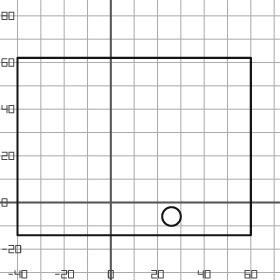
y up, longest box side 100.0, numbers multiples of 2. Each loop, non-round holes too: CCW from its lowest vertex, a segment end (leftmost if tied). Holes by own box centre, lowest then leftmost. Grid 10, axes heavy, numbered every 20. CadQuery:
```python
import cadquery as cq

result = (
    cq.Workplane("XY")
    .moveTo(-40.0, -14.0)
    .lineTo(60.0, -14.0)
    .lineTo(60.0, 62.0)
    .lineTo(-40.0, 62.0)
    .close()
    .moveTo(26.0, -6.0)
    .circle(4.0)
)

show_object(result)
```